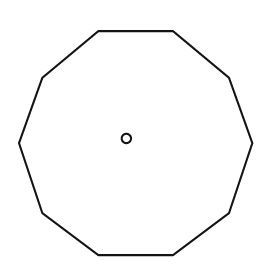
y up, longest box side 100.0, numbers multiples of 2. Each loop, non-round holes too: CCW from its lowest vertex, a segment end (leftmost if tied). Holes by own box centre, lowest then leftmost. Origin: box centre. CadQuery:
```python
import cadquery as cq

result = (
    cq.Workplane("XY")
    .moveTo(-16.0, -48.0)
    .lineTo(16.0, -48.0)
    .lineTo(40.0, -30.0)
    .lineTo(50.0, 0.0)
    .lineTo(40.0, 28.0)
    .lineTo(16.0, 48.0)
    .lineTo(-16.0, 48.0)
    .lineTo(-40.0, 28.0)
    .lineTo(-50.0, 0.0)
    .lineTo(-40.0, -30.0)
    .close()
    .moveTo(-4.0, 2.0)
    .circle(2.0)
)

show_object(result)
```